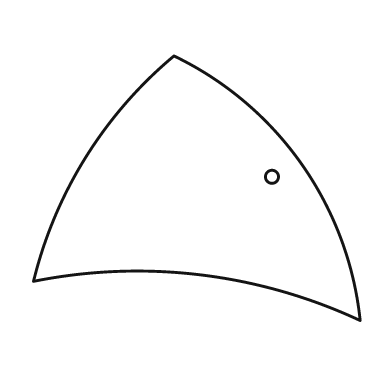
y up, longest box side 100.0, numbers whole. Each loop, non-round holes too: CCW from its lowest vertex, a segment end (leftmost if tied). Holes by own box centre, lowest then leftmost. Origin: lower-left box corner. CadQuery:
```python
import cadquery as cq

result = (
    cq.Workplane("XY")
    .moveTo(100.0, 0.0)
    .threePointArc((82.0, 48.0), (43.0, 81.0))
    .threePointArc((16.0, 50.0), (0.0, 12.0))
    .threePointArc((51.0, 14.0), (100.0, 0.0))
    .close()
    .moveTo(73.0, 44.0)
    .circle(2.0)
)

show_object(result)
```